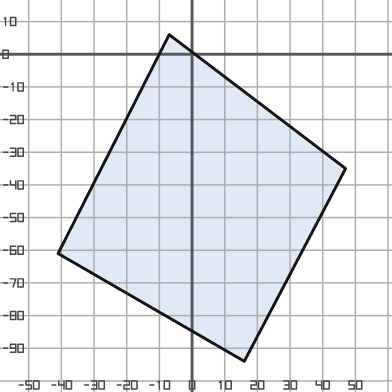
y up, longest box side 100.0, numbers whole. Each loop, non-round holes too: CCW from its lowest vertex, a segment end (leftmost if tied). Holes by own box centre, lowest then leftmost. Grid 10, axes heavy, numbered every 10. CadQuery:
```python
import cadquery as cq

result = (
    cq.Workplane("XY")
    .moveTo(16.0, -94.0)
    .lineTo(47.0, -35.0)
    .lineTo(-7.0, 6.0)
    .lineTo(-41.0, -61.0)
    .close()
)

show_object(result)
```